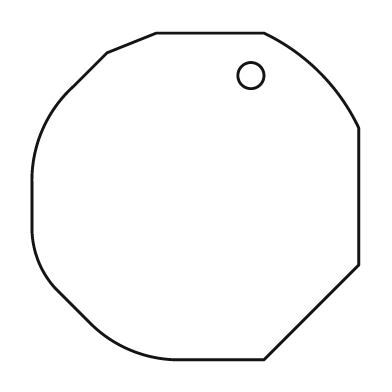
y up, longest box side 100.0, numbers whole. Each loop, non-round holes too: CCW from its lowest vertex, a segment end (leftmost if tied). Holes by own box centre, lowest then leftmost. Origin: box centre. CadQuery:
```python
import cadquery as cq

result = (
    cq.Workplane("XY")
    .moveTo(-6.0, -50.0)
    .lineTo(21.0, -50.0)
    .lineTo(50.0, -21.0)
    .lineTo(50.0, 21.0)
    .threePointArc((38.0, 38.0), (21.0, 50.0))
    .lineTo(-12.0, 50.0)
    .lineTo(-27.0, 44.0)
    .lineTo(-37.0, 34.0)
    .threePointArc((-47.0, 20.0), (-50.0, 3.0))
    .lineTo(-50.0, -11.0)
    .threePointArc((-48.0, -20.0), (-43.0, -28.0))
    .lineTo(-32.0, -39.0)
    .threePointArc((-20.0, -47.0), (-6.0, -50.0))
    .close()
    .moveTo(17.0, 37.0)
    .circle(4.0)
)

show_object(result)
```